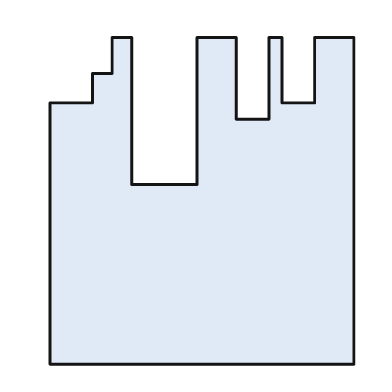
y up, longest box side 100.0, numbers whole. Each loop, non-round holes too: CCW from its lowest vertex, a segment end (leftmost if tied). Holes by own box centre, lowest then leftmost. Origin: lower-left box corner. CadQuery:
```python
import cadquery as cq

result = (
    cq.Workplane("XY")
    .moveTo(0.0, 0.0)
    .lineTo(93.0, 0.0)
    .lineTo(93.0, 100.0)
    .lineTo(81.0, 100.0)
    .lineTo(81.0, 80.0)
    .lineTo(71.0, 80.0)
    .lineTo(71.0, 100.0)
    .lineTo(67.0, 100.0)
    .lineTo(67.0, 75.0)
    .lineTo(57.0, 75.0)
    .lineTo(57.0, 100.0)
    .lineTo(45.0, 100.0)
    .lineTo(45.0, 55.0)
    .lineTo(25.0, 55.0)
    .lineTo(25.0, 100.0)
    .lineTo(19.0, 100.0)
    .lineTo(19.0, 89.0)
    .lineTo(13.0, 89.0)
    .lineTo(13.0, 80.0)
    .lineTo(0.0, 80.0)
    .close()
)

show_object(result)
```